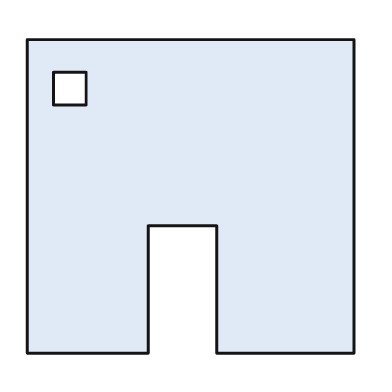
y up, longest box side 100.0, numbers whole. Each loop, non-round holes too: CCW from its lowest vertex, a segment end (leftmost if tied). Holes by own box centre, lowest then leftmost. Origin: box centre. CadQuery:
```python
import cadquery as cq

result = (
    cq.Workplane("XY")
    .moveTo(-50.0, -48.0)
    .lineTo(-13.0, -48.0)
    .lineTo(-13.0, -9.0)
    .lineTo(8.0, -9.0)
    .lineTo(8.0, -48.0)
    .lineTo(50.0, -48.0)
    .lineTo(50.0, 48.0)
    .lineTo(-50.0, 48.0)
    .close()
    .moveTo(-42.0, 28.0)
    .lineTo(-32.0, 28.0)
    .lineTo(-32.0, 38.0)
    .lineTo(-42.0, 38.0)
    .close()
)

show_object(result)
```